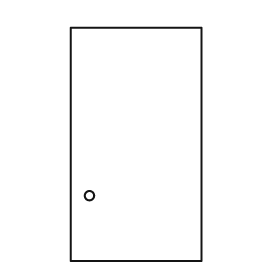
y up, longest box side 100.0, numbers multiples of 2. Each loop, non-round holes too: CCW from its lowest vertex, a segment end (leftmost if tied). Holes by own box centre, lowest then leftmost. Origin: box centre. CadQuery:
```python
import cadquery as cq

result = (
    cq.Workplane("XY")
    .moveTo(-28.0, -50.0)
    .lineTo(28.0, -50.0)
    .lineTo(28.0, 50.0)
    .lineTo(-28.0, 50.0)
    .close()
    .moveTo(-20.0, -22.0)
    .circle(2.0)
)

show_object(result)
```